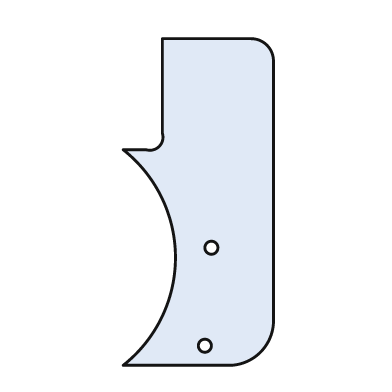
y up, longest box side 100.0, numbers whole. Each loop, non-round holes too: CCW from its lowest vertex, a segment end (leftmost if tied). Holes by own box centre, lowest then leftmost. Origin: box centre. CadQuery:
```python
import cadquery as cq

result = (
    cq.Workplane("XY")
    .moveTo(-23.0, -50.0)
    .lineTo(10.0, -50.0)
    .threePointArc((19.0, -46.0), (23.0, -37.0))
    .lineTo(23.0, 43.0)
    .threePointArc((21.0, 48.0), (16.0, 50.0))
    .lineTo(-11.0, 50.0)
    .lineTo(-11.0, 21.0)
    .threePointArc((-12.0, 17.0), (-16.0, 16.0))
    .lineTo(-23.0, 16.0)
    .threePointArc((-7.0, -17.0), (-23.0, -50.0))
    .close()
    .moveTo(2.0, -44.0)
    .circle(2.0)
    .moveTo(4.0, -14.0)
    .circle(2.0)
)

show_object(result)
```